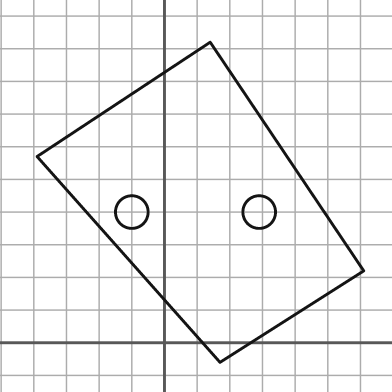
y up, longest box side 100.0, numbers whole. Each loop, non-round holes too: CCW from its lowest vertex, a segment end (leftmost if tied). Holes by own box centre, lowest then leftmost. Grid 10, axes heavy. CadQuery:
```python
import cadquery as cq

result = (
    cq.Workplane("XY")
    .moveTo(17.0, -6.0)
    .lineTo(61.0, 22.0)
    .lineTo(14.0, 92.0)
    .lineTo(-39.0, 57.0)
    .close()
    .moveTo(-10.0, 40.0)
    .circle(5.0)
    .moveTo(29.0, 40.0)
    .circle(5.0)
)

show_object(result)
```